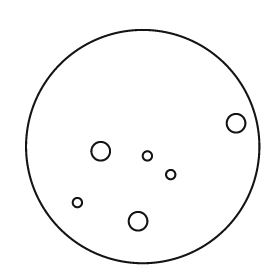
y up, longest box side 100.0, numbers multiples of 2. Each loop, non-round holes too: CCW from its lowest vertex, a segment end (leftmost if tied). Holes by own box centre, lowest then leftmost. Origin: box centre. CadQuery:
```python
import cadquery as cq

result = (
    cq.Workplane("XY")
    .moveTo(0.0, 0.0)
    .circle(50.0)
    .moveTo(-2.0, -32.0)
    .circle(4.0)
    .moveTo(-28.0, -24.0)
    .circle(2.0)
    .moveTo(12.0, -12.0)
    .circle(2.0)
    .moveTo(2.0, -4.0)
    .circle(2.0)
    .moveTo(-18.0, -2.0)
    .circle(4.0)
    .moveTo(40.0, 10.0)
    .circle(4.0)
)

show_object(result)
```